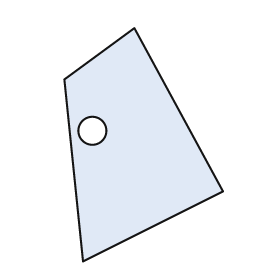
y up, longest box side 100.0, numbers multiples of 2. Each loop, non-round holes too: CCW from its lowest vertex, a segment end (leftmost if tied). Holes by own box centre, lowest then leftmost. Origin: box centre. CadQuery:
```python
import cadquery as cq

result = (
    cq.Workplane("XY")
    .moveTo(-26.0, -50.0)
    .lineTo(34.0, -20.0)
    .lineTo(-4.0, 50.0)
    .lineTo(-34.0, 28.0)
    .close()
    .moveTo(-22.0, 6.0)
    .circle(6.0)
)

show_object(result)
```